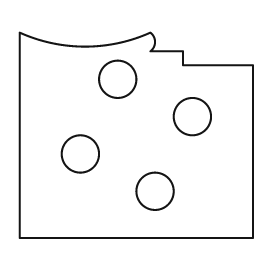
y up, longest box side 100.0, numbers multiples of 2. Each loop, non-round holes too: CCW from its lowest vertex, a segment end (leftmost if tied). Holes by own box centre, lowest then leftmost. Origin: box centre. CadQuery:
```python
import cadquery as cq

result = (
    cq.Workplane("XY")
    .moveTo(-50.0, -44.0)
    .lineTo(50.0, -44.0)
    .lineTo(50.0, 30.0)
    .lineTo(20.0, 30.0)
    .lineTo(20.0, 36.0)
    .lineTo(6.0, 36.0)
    .threePointArc((8.0, 40.0), (6.0, 44.0))
    .threePointArc((-22.0, 38.0), (-50.0, 44.0))
    .close()
    .moveTo(8.0, -24.0)
    .circle(8.0)
    .moveTo(-24.0, -8.0)
    .circle(8.0)
    .moveTo(24.0, 8.0)
    .circle(8.0)
    .moveTo(-8.0, 24.0)
    .circle(8.0)
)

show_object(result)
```